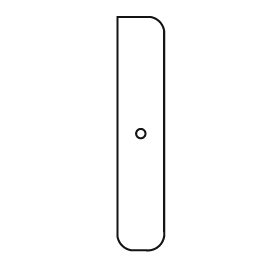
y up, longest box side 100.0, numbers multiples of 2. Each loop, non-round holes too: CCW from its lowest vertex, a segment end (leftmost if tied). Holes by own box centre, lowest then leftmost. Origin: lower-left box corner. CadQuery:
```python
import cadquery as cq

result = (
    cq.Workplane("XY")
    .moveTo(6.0, 0.0)
    .lineTo(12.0, 0.0)
    .threePointArc((18.0, 2.0), (20.0, 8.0))
    .lineTo(20.0, 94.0)
    .threePointArc((18.0, 98.0), (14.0, 100.0))
    .lineTo(0.0, 100.0)
    .lineTo(0.0, 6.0)
    .threePointArc((2.0, 2.0), (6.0, 0.0))
    .close()
    .moveTo(10.0, 50.0)
    .circle(2.0)
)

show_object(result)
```